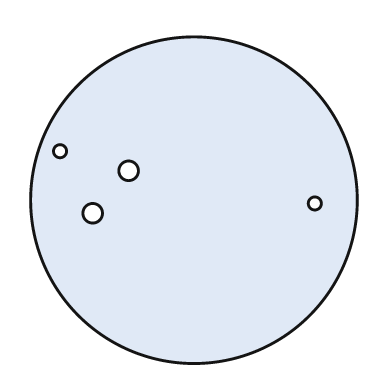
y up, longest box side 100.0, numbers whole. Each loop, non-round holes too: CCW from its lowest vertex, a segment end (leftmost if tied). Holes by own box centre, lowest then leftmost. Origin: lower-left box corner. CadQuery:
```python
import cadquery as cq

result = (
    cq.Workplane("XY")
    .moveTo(50.0, 50.0)
    .circle(50.0)
    .moveTo(19.0, 46.0)
    .circle(3.0)
    .moveTo(87.0, 49.0)
    .circle(2.0)
    .moveTo(30.0, 59.0)
    .circle(3.0)
    .moveTo(9.0, 65.0)
    .circle(2.0)
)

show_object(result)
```